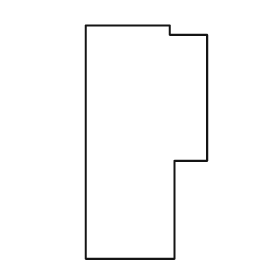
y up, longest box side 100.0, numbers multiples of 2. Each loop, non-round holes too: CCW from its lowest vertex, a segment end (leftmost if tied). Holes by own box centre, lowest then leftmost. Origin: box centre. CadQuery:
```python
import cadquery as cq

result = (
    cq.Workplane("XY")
    .moveTo(-26.0, -50.0)
    .lineTo(12.0, -50.0)
    .lineTo(12.0, -8.0)
    .lineTo(26.0, -8.0)
    .lineTo(26.0, 46.0)
    .lineTo(10.0, 46.0)
    .lineTo(10.0, 50.0)
    .lineTo(-26.0, 50.0)
    .close()
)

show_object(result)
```